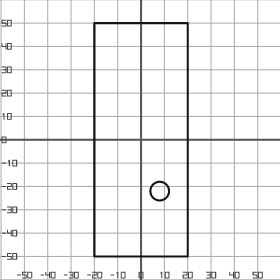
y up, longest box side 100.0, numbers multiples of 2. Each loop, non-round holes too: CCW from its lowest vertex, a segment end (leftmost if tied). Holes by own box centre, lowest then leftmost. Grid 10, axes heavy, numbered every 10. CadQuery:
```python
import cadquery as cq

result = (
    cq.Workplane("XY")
    .moveTo(-20.0, -50.0)
    .lineTo(20.0, -50.0)
    .lineTo(20.0, 50.0)
    .lineTo(-20.0, 50.0)
    .close()
    .moveTo(8.0, -22.0)
    .circle(4.0)
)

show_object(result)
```